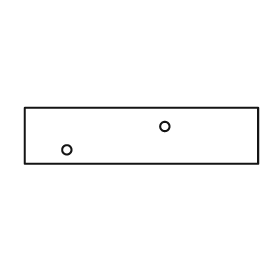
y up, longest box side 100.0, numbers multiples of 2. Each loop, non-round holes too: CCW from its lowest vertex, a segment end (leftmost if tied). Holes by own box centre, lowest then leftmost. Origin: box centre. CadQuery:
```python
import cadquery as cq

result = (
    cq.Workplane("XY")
    .moveTo(-50.0, -12.0)
    .lineTo(50.0, -12.0)
    .lineTo(50.0, 12.0)
    .lineTo(-50.0, 12.0)
    .close()
    .moveTo(-32.0, -6.0)
    .circle(2.0)
    .moveTo(10.0, 4.0)
    .circle(2.0)
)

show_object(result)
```